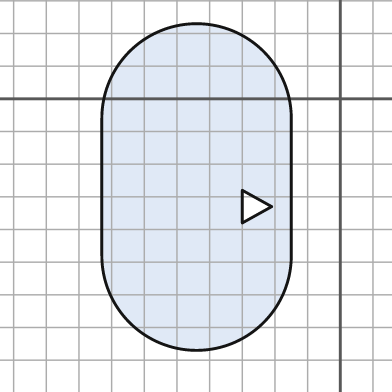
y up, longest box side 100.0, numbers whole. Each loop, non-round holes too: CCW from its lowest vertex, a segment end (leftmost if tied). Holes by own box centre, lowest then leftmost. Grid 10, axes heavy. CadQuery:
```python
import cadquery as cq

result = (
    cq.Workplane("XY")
    .moveTo(-73.0, -48.0)
    .threePointArc((-44.0, -77.0), (-15.0, -48.0))
    .lineTo(-15.0, -6.0)
    .threePointArc((-44.0, 23.0), (-73.0, -6.0))
    .close()
    .moveTo(-30.0, -38.0)
    .lineTo(-21.0, -33.0)
    .lineTo(-30.0, -28.0)
    .close()
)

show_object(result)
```